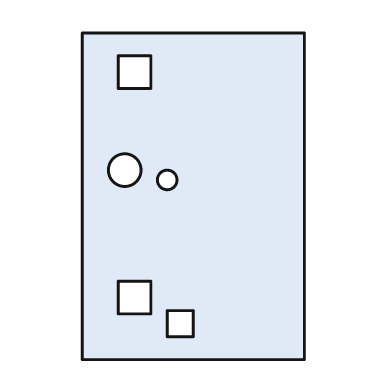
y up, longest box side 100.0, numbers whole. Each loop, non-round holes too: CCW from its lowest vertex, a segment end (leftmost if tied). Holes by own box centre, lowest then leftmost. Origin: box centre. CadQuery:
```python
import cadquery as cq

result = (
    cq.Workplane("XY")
    .moveTo(-34.0, -50.0)
    .lineTo(34.0, -50.0)
    .lineTo(34.0, 50.0)
    .lineTo(-34.0, 50.0)
    .close()
    .moveTo(-8.0, -43.0)
    .lineTo(0.0, -43.0)
    .lineTo(0.0, -35.0)
    .lineTo(-8.0, -35.0)
    .close()
    .moveTo(-23.0, -36.0)
    .lineTo(-13.0, -36.0)
    .lineTo(-13.0, -26.0)
    .lineTo(-23.0, -26.0)
    .close()
    .moveTo(-8.0, 5.0)
    .circle(3.0)
    .moveTo(-21.0, 8.0)
    .circle(5.0)
    .moveTo(-23.0, 33.0)
    .lineTo(-13.0, 33.0)
    .lineTo(-13.0, 43.0)
    .lineTo(-23.0, 43.0)
    .close()
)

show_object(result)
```